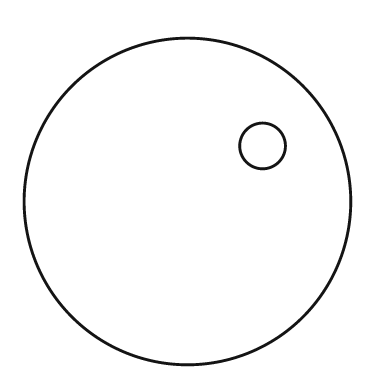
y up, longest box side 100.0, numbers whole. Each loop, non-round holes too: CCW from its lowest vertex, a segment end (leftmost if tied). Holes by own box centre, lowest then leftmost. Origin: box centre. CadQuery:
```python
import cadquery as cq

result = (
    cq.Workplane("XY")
    .moveTo(0.0, 0.0)
    .circle(50.0)
    .moveTo(23.0, 17.0)
    .circle(7.0)
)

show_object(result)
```